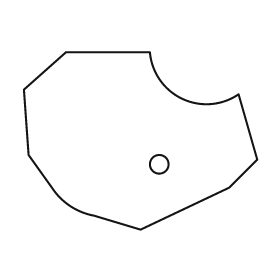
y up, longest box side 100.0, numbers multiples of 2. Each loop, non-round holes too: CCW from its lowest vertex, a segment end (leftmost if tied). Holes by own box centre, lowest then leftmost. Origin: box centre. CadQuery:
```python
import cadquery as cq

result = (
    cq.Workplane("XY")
    .moveTo(0.0, -38.0)
    .lineTo(38.0, -20.0)
    .lineTo(50.0, -8.0)
    .lineTo(42.0, 20.0)
    .threePointArc((18.0, 18.0), (4.0, 38.0))
    .lineTo(-32.0, 38.0)
    .lineTo(-50.0, 22.0)
    .lineTo(-48.0, -6.0)
    .lineTo(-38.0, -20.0)
    .threePointArc((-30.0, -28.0), (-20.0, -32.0))
    .close()
    .moveTo(8.0, -10.0)
    .circle(4.0)
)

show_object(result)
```